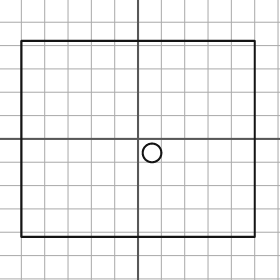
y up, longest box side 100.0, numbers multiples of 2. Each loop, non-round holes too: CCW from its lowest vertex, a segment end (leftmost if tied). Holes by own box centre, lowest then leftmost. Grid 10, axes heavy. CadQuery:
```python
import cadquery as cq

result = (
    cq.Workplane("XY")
    .moveTo(-50.0, -42.0)
    .lineTo(50.0, -42.0)
    .lineTo(50.0, 42.0)
    .lineTo(-50.0, 42.0)
    .close()
    .moveTo(6.0, -6.0)
    .circle(4.0)
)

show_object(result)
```